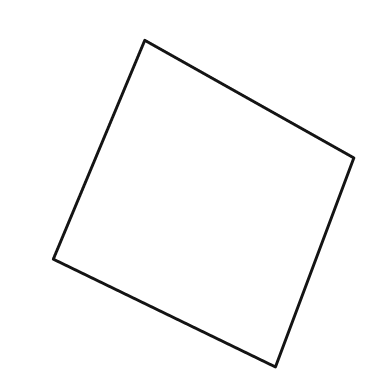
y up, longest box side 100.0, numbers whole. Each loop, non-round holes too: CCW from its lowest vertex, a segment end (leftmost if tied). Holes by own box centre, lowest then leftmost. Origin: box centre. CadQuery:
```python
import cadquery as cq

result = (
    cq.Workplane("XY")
    .moveTo(22.0, -50.0)
    .lineTo(46.0, 14.0)
    .lineTo(-18.0, 50.0)
    .lineTo(-46.0, -17.0)
    .close()
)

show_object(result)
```